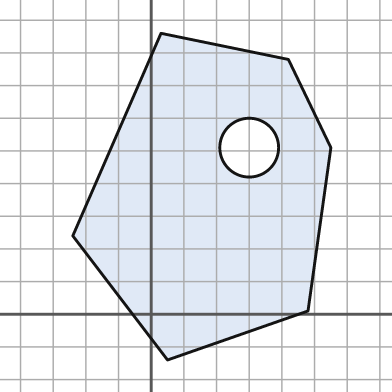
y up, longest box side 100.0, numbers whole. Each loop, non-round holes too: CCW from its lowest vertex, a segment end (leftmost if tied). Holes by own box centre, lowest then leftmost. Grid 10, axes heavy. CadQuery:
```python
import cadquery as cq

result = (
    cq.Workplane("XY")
    .moveTo(5.0, -14.0)
    .lineTo(48.0, 1.0)
    .lineTo(55.0, 51.0)
    .lineTo(42.0, 78.0)
    .lineTo(3.0, 86.0)
    .lineTo(-24.0, 24.0)
    .close()
    .moveTo(30.0, 51.0)
    .circle(9.0)
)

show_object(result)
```